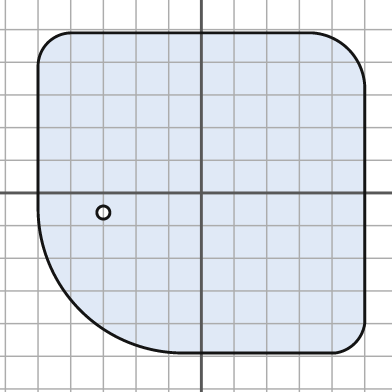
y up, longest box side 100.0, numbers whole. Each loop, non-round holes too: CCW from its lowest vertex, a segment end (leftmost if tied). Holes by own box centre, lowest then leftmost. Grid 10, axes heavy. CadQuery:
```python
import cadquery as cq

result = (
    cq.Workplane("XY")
    .moveTo(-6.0, -49.0)
    .lineTo(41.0, -49.0)
    .threePointArc((47.0, -46.0), (50.0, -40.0))
    .lineTo(50.0, 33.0)
    .threePointArc((45.0, 44.0), (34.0, 49.0))
    .lineTo(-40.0, 49.0)
    .threePointArc((-47.0, 46.0), (-50.0, 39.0))
    .lineTo(-50.0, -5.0)
    .threePointArc((-37.0, -36.0), (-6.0, -49.0))
    .close()
    .moveTo(-30.0, -6.0)
    .circle(2.0)
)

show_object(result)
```